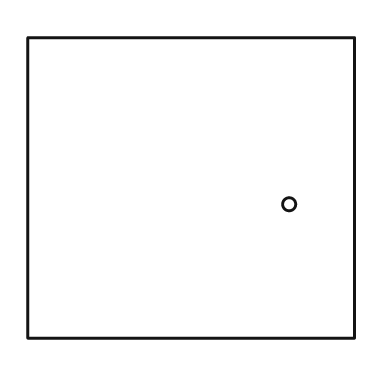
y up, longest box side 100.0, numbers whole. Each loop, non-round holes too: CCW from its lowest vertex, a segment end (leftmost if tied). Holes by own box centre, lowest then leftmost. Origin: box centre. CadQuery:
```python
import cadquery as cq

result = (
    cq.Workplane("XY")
    .moveTo(-50.0, -46.0)
    .lineTo(50.0, -46.0)
    .lineTo(50.0, 46.0)
    .lineTo(-50.0, 46.0)
    .close()
    .moveTo(30.0, -5.0)
    .circle(2.0)
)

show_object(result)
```